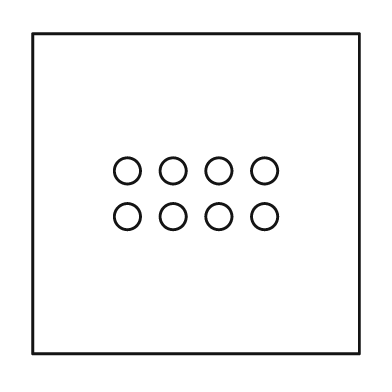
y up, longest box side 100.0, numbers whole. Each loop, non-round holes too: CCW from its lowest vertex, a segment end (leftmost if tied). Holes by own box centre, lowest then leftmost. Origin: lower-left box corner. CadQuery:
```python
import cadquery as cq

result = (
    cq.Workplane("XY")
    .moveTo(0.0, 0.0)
    .lineTo(100.0, 0.0)
    .lineTo(100.0, 98.0)
    .lineTo(0.0, 98.0)
    .close()
    .moveTo(29.0, 42.0)
    .circle(4.0)
    .moveTo(43.0, 42.0)
    .circle(4.0)
    .moveTo(57.0, 42.0)
    .circle(4.0)
    .moveTo(71.0, 42.0)
    .circle(4.0)
    .moveTo(29.0, 56.0)
    .circle(4.0)
    .moveTo(43.0, 56.0)
    .circle(4.0)
    .moveTo(57.0, 56.0)
    .circle(4.0)
    .moveTo(71.0, 56.0)
    .circle(4.0)
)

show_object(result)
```